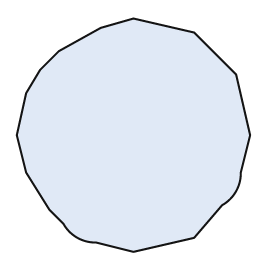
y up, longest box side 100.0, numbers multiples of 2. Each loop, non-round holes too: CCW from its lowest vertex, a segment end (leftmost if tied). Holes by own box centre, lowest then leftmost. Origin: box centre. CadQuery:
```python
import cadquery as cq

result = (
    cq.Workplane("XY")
    .moveTo(0.0, -50.0)
    .lineTo(26.0, -44.0)
    .lineTo(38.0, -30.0)
    .threePointArc((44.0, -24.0), (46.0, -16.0))
    .lineTo(50.0, 0.0)
    .lineTo(44.0, 26.0)
    .lineTo(26.0, 44.0)
    .lineTo(0.0, 50.0)
    .lineTo(-14.0, 46.0)
    .lineTo(-32.0, 36.0)
    .lineTo(-40.0, 28.0)
    .lineTo(-46.0, 18.0)
    .lineTo(-50.0, 0.0)
    .lineTo(-46.0, -16.0)
    .lineTo(-36.0, -32.0)
    .lineTo(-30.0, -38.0)
    .threePointArc((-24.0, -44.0), (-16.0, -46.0))
    .close()
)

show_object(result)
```